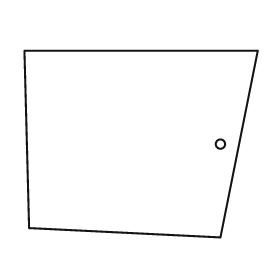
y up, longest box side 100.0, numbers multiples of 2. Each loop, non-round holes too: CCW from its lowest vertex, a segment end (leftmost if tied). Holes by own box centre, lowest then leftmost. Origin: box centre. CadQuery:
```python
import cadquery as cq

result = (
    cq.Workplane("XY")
    .moveTo(34.0, -40.0)
    .lineTo(50.0, 40.0)
    .lineTo(-50.0, 40.0)
    .lineTo(-48.0, -36.0)
    .close()
    .moveTo(34.0, 0.0)
    .circle(2.0)
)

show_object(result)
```